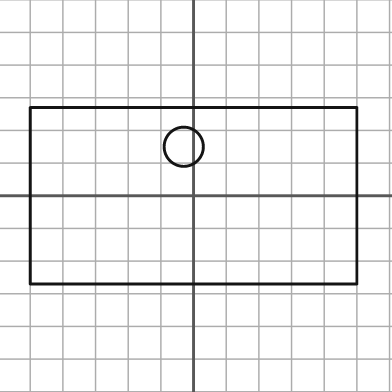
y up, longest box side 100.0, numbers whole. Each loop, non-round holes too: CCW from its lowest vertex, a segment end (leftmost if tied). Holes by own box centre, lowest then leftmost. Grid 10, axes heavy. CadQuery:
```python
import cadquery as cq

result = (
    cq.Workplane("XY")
    .moveTo(-50.0, -27.0)
    .lineTo(50.0, -27.0)
    .lineTo(50.0, 27.0)
    .lineTo(-50.0, 27.0)
    .close()
    .moveTo(-3.0, 15.0)
    .circle(6.0)
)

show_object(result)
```